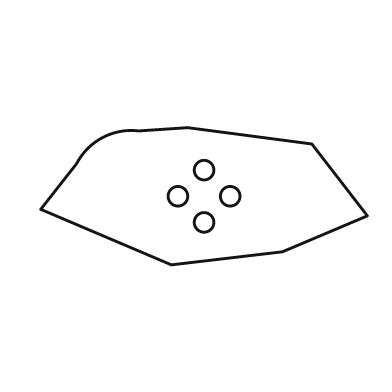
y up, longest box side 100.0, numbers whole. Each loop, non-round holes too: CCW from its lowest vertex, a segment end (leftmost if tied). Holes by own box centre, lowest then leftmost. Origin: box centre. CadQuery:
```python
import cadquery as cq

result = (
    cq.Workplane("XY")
    .moveTo(-10.0, -21.0)
    .lineTo(24.0, -17.0)
    .lineTo(50.0, -6.0)
    .lineTo(33.0, 16.0)
    .lineTo(-5.0, 21.0)
    .lineTo(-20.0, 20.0)
    .threePointArc((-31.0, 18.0), (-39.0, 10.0))
    .lineTo(-50.0, -4.0)
    .close()
    .moveTo(0.0, -8.0)
    .circle(3.0)
    .moveTo(-8.0, 0.0)
    .circle(3.0)
    .moveTo(8.0, 0.0)
    .circle(3.0)
    .moveTo(0.0, 8.0)
    .circle(3.0)
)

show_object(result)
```